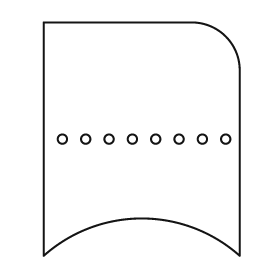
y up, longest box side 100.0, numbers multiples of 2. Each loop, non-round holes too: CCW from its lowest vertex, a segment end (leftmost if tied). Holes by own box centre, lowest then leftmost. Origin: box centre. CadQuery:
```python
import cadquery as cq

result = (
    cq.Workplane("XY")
    .moveTo(-42.0, -50.0)
    .threePointArc((0.0, -34.0), (42.0, -50.0))
    .lineTo(42.0, 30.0)
    .threePointArc((36.0, 44.0), (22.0, 50.0))
    .lineTo(-42.0, 50.0)
    .close()
    .moveTo(-34.0, 0.0)
    .circle(2.0)
    .moveTo(-24.0, 0.0)
    .circle(2.0)
    .moveTo(-14.0, 0.0)
    .circle(2.0)
    .moveTo(-4.0, 0.0)
    .circle(2.0)
    .moveTo(6.0, 0.0)
    .circle(2.0)
    .moveTo(16.0, 0.0)
    .circle(2.0)
    .moveTo(26.0, 0.0)
    .circle(2.0)
    .moveTo(36.0, 0.0)
    .circle(2.0)
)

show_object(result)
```